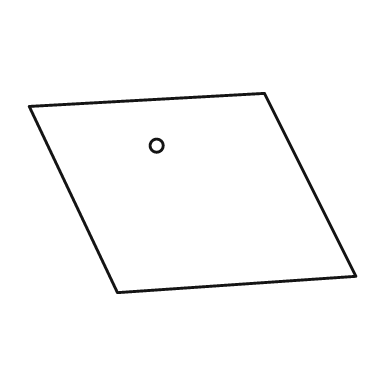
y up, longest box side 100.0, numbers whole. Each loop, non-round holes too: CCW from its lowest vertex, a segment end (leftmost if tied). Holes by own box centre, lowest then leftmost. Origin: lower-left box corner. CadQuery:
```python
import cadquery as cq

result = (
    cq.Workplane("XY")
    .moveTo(27.0, 0.0)
    .lineTo(100.0, 5.0)
    .lineTo(72.0, 61.0)
    .lineTo(0.0, 57.0)
    .close()
    .moveTo(39.0, 45.0)
    .circle(2.0)
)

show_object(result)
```